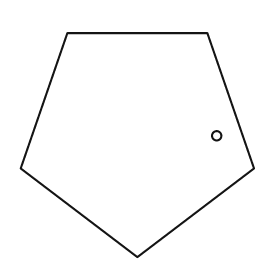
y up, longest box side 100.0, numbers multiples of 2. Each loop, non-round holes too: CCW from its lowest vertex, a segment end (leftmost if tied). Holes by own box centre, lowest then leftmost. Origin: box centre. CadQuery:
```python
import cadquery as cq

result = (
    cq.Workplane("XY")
    .moveTo(0.0, -48.0)
    .lineTo(50.0, -10.0)
    .lineTo(30.0, 48.0)
    .lineTo(-30.0, 48.0)
    .lineTo(-50.0, -10.0)
    .close()
    .moveTo(34.0, 4.0)
    .circle(2.0)
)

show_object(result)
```